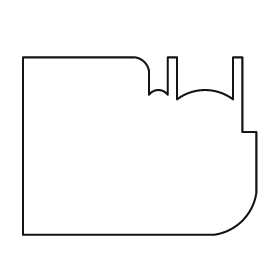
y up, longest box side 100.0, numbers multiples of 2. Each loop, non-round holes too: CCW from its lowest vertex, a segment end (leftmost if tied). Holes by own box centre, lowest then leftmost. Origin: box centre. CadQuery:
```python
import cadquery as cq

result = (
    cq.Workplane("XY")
    .moveTo(-50.0, -38.0)
    .lineTo(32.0, -38.0)
    .threePointArc((44.0, -32.0), (50.0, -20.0))
    .lineTo(50.0, 6.0)
    .lineTo(44.0, 6.0)
    .lineTo(44.0, 38.0)
    .lineTo(40.0, 38.0)
    .lineTo(40.0, 20.0)
    .threePointArc((28.0, 24.0), (16.0, 20.0))
    .lineTo(16.0, 38.0)
    .lineTo(12.0, 38.0)
    .lineTo(12.0, 22.0)
    .threePointArc((8.0, 24.0), (4.0, 22.0))
    .lineTo(4.0, 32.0)
    .threePointArc((2.0, 36.0), (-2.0, 38.0))
    .lineTo(-50.0, 38.0)
    .close()
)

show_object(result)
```